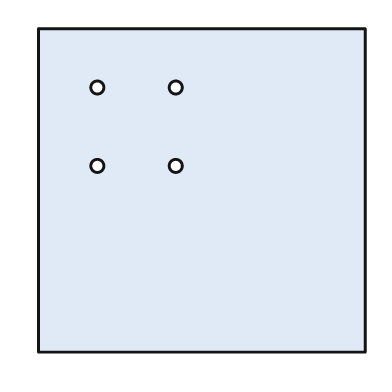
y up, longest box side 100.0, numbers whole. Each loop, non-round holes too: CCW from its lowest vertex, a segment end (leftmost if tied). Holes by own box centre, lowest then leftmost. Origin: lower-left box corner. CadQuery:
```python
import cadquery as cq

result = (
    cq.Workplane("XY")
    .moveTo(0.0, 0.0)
    .lineTo(100.0, 0.0)
    .lineTo(100.0, 99.0)
    .lineTo(0.0, 99.0)
    .close()
    .moveTo(18.0, 57.0)
    .circle(2.0)
    .moveTo(42.0, 57.0)
    .circle(2.0)
    .moveTo(18.0, 81.0)
    .circle(2.0)
    .moveTo(42.0, 81.0)
    .circle(2.0)
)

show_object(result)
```